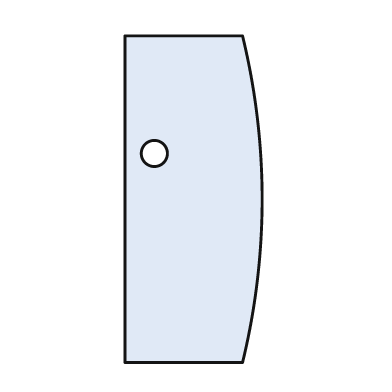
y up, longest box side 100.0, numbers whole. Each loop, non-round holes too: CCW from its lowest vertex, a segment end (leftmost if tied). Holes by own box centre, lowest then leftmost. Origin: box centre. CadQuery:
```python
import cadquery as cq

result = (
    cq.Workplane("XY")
    .moveTo(-21.0, -50.0)
    .lineTo(15.0, -50.0)
    .threePointArc((21.0, 0.0), (15.0, 50.0))
    .lineTo(-21.0, 50.0)
    .close()
    .moveTo(-12.0, 14.0)
    .circle(4.0)
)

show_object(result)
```